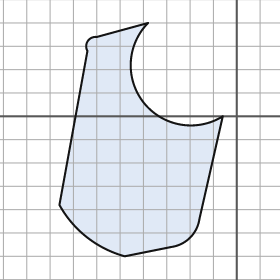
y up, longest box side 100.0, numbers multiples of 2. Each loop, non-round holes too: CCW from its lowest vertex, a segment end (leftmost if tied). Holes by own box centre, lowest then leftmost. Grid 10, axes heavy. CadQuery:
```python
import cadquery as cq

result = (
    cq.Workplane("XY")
    .moveTo(-48.0, -60.0)
    .lineTo(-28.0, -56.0)
    .threePointArc((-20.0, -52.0), (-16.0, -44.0))
    .lineTo(-6.0, 0.0)
    .threePointArc((-40.0, 6.0), (-38.0, 40.0))
    .lineTo(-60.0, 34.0)
    .threePointArc((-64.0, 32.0), (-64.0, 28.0))
    .lineTo(-76.0, -38.0)
    .threePointArc((-64.0, -52.0), (-48.0, -60.0))
    .close()
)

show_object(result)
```